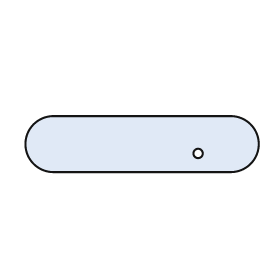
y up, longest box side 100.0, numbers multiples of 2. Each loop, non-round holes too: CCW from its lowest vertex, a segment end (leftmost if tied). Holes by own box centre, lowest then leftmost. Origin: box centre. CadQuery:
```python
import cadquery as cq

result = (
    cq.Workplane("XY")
    .moveTo(-38.0, -12.0)
    .lineTo(38.0, -12.0)
    .threePointArc((50.0, 0.0), (38.0, 12.0))
    .lineTo(-38.0, 12.0)
    .threePointArc((-50.0, 0.0), (-38.0, -12.0))
    .close()
    .moveTo(24.0, -4.0)
    .circle(2.0)
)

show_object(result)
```